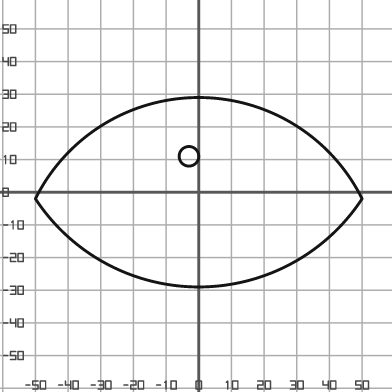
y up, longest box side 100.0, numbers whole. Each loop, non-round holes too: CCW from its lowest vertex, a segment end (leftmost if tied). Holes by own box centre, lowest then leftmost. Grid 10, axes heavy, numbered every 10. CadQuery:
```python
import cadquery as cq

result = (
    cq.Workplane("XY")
    .moveTo(-50.0, -2.0)
    .threePointArc((0.0, -29.0), (50.0, -2.0))
    .threePointArc((0.0, 29.0), (-50.0, -2.0))
    .close()
    .moveTo(-3.0, 11.0)
    .circle(3.0)
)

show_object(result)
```